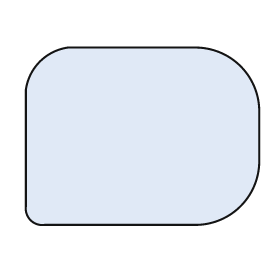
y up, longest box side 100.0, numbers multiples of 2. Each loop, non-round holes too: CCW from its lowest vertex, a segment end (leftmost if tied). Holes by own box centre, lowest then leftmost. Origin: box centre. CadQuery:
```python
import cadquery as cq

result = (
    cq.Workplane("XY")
    .moveTo(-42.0, -38.0)
    .lineTo(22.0, -38.0)
    .threePointArc((42.0, -30.0), (50.0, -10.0))
    .lineTo(50.0, 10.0)
    .threePointArc((42.0, 30.0), (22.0, 38.0))
    .lineTo(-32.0, 38.0)
    .threePointArc((-44.0, 32.0), (-50.0, 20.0))
    .lineTo(-50.0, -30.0)
    .threePointArc((-48.0, -36.0), (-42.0, -38.0))
    .close()
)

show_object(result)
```